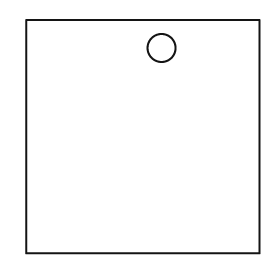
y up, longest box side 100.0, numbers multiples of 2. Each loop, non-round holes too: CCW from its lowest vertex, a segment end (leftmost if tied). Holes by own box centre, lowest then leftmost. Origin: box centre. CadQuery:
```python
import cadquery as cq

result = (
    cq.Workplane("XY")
    .moveTo(-50.0, -50.0)
    .lineTo(50.0, -50.0)
    .lineTo(50.0, 50.0)
    .lineTo(-50.0, 50.0)
    .close()
    .moveTo(8.0, 38.0)
    .circle(6.0)
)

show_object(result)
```